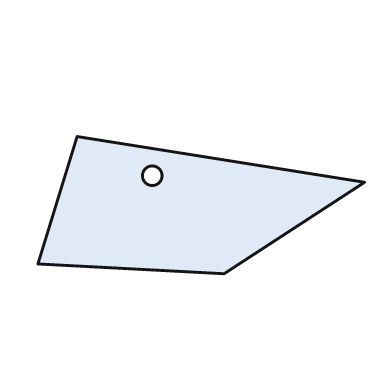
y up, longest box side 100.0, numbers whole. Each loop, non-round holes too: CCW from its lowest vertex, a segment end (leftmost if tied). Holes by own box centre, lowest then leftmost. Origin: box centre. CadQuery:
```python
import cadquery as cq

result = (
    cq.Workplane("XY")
    .moveTo(7.0, -21.0)
    .lineTo(50.0, 7.0)
    .lineTo(-38.0, 21.0)
    .lineTo(-50.0, -18.0)
    .close()
    .moveTo(-15.0, 9.0)
    .circle(3.0)
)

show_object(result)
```